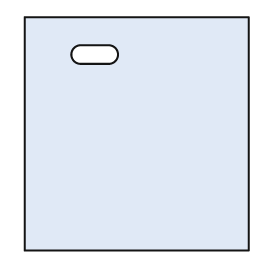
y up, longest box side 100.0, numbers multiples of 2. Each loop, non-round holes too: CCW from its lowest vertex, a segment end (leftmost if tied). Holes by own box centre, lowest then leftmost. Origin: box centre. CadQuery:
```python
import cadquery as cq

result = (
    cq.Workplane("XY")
    .moveTo(-48.0, -50.0)
    .lineTo(48.0, -50.0)
    .lineTo(48.0, 50.0)
    .lineTo(-48.0, 50.0)
    .close()
    .moveTo(-24.0, 30.0)
    .lineTo(-12.0, 30.0)
    .threePointArc((-8.0, 34.0), (-12.0, 38.0))
    .lineTo(-24.0, 38.0)
    .threePointArc((-28.0, 34.0), (-24.0, 30.0))
    .close()
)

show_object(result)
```